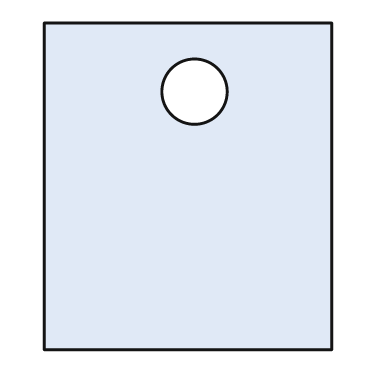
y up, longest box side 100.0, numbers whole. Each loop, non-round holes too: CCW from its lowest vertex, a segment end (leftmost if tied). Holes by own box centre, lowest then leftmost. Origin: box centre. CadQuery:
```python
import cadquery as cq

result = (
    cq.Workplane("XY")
    .moveTo(-44.0, -50.0)
    .lineTo(44.0, -50.0)
    .lineTo(44.0, 50.0)
    .lineTo(-44.0, 50.0)
    .close()
    .moveTo(2.0, 29.0)
    .circle(10.0)
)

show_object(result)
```